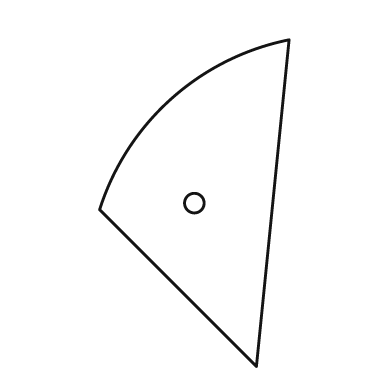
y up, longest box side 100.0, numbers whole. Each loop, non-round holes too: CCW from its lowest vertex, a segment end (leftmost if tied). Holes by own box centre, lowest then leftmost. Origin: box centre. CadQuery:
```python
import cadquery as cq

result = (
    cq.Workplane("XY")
    .moveTo(19.0, -50.0)
    .lineTo(29.0, 50.0)
    .threePointArc((-7.0, 32.0), (-29.0, -2.0))
    .close()
    .moveTo(0.0, 0.0)
    .circle(3.0)
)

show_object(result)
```